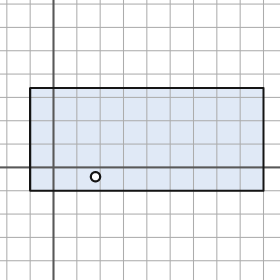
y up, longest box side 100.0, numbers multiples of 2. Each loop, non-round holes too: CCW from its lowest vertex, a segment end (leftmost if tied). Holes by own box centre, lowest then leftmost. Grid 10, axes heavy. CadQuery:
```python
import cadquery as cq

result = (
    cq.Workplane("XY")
    .moveTo(-10.0, -10.0)
    .lineTo(90.0, -10.0)
    .lineTo(90.0, 34.0)
    .lineTo(-10.0, 34.0)
    .close()
    .moveTo(18.0, -4.0)
    .circle(2.0)
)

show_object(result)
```